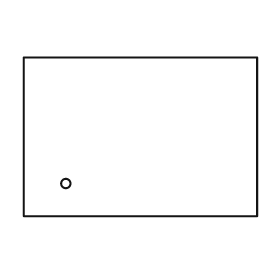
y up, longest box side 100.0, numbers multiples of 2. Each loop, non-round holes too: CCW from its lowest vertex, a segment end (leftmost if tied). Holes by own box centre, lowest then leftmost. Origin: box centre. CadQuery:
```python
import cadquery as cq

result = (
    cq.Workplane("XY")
    .moveTo(-50.0, -34.0)
    .lineTo(50.0, -34.0)
    .lineTo(50.0, 34.0)
    .lineTo(-50.0, 34.0)
    .close()
    .moveTo(-32.0, -20.0)
    .circle(2.0)
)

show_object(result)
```